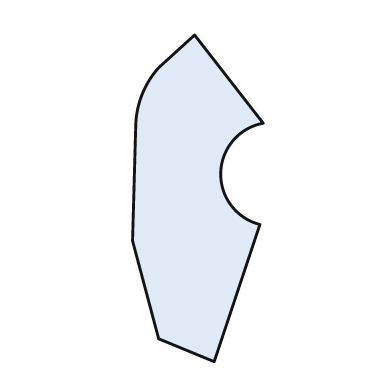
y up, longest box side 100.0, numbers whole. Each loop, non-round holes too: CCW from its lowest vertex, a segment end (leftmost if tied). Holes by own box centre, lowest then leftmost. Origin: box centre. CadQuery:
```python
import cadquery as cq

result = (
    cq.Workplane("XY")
    .moveTo(5.0, -50.0)
    .lineTo(19.0, -8.0)
    .threePointArc((7.0, 8.0), (20.0, 23.0))
    .lineTo(-1.0, 50.0)
    .lineTo(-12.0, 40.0)
    .threePointArc((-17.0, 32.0), (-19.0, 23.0))
    .lineTo(-20.0, -13.0)
    .lineTo(-12.0, -43.0)
    .close()
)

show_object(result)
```